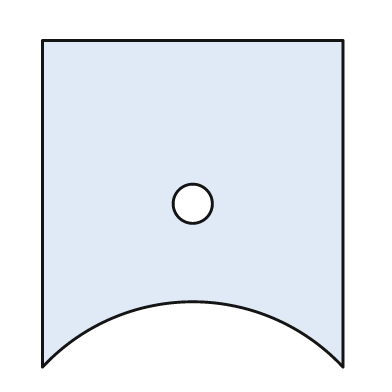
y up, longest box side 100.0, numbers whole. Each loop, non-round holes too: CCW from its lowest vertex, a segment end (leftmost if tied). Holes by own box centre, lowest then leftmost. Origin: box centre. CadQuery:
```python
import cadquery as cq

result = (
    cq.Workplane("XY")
    .moveTo(-46.0, -50.0)
    .threePointArc((0.0, -30.0), (46.0, -50.0))
    .lineTo(46.0, 50.0)
    .lineTo(-46.0, 50.0)
    .close()
    .moveTo(0.0, 0.0)
    .circle(6.0)
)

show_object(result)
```